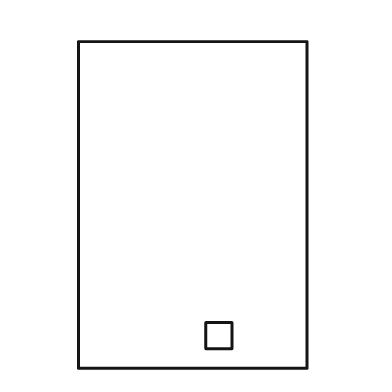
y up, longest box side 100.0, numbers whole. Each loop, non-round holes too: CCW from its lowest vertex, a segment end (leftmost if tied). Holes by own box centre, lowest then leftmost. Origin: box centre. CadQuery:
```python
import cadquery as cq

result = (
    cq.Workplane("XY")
    .moveTo(-35.0, -50.0)
    .lineTo(35.0, -50.0)
    .lineTo(35.0, 50.0)
    .lineTo(-35.0, 50.0)
    .close()
    .moveTo(4.0, -44.0)
    .lineTo(12.0, -44.0)
    .lineTo(12.0, -36.0)
    .lineTo(4.0, -36.0)
    .close()
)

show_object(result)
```